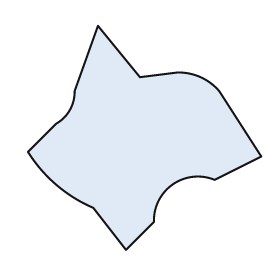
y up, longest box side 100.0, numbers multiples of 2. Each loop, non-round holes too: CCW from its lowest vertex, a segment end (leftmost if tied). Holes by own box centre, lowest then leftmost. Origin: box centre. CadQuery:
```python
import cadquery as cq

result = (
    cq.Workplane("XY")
    .moveTo(-8.0, -48.0)
    .lineTo(4.0, -36.0)
    .threePointArc((12.0, -20.0), (30.0, -18.0))
    .lineTo(50.0, -8.0)
    .lineTo(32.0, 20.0)
    .threePointArc((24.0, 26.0), (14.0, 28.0))
    .lineTo(-2.0, 26.0)
    .lineTo(-20.0, 48.0)
    .lineTo(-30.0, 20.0)
    .threePointArc((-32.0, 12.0), (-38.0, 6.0))
    .lineTo(-50.0, -6.0)
    .threePointArc((-38.0, -20.0), (-22.0, -30.0))
    .close()
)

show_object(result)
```